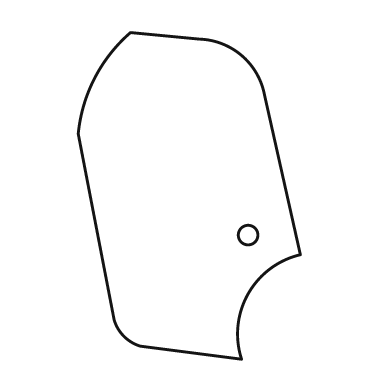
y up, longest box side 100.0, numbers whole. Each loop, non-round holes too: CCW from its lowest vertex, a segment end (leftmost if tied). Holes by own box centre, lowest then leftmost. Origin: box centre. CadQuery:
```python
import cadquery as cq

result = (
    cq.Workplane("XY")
    .moveTo(16.0, -50.0)
    .threePointArc((18.0, -30.0), (34.0, -18.0))
    .lineTo(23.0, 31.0)
    .threePointArc((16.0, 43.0), (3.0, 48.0))
    .lineTo(-18.0, 50.0)
    .threePointArc((-29.0, 36.0), (-34.0, 19.0))
    .lineTo(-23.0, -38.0)
    .threePointArc((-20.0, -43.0), (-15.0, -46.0))
    .close()
    .moveTo(18.0, -12.0)
    .circle(3.0)
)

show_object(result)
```